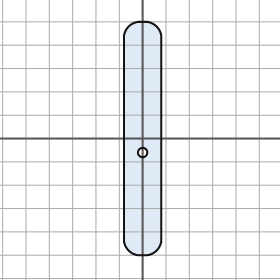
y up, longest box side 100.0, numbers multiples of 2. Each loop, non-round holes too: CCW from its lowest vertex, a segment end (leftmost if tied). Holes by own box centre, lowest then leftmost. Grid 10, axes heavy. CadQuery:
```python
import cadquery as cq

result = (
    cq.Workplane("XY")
    .moveTo(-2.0, -50.0)
    .lineTo(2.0, -50.0)
    .threePointArc((6.0, -48.0), (8.0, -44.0))
    .lineTo(8.0, 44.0)
    .threePointArc((6.0, 48.0), (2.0, 50.0))
    .lineTo(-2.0, 50.0)
    .threePointArc((-6.0, 48.0), (-8.0, 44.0))
    .lineTo(-8.0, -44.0)
    .threePointArc((-6.0, -48.0), (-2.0, -50.0))
    .close()
    .moveTo(0.0, -6.0)
    .circle(2.0)
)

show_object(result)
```